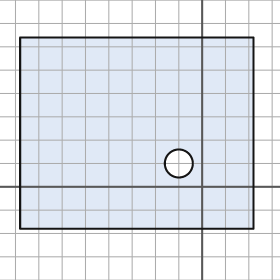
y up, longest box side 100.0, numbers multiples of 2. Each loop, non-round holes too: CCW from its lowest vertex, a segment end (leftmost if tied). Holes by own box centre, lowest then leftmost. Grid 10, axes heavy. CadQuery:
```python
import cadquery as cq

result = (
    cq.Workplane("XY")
    .moveTo(-78.0, -18.0)
    .lineTo(22.0, -18.0)
    .lineTo(22.0, 64.0)
    .lineTo(-78.0, 64.0)
    .close()
    .moveTo(-10.0, 10.0)
    .circle(6.0)
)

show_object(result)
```